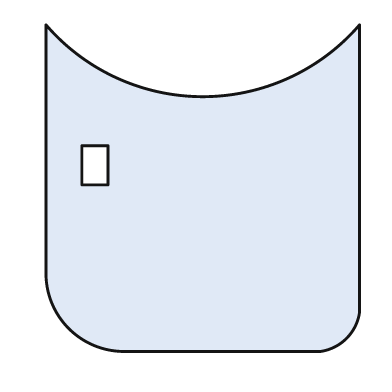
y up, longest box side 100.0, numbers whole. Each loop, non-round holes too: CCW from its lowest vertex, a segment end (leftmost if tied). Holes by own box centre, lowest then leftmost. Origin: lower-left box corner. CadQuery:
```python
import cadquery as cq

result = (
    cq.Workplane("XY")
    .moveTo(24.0, 0.0)
    .lineTo(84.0, 0.0)
    .threePointArc((92.0, 4.0), (96.0, 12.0))
    .lineTo(96.0, 100.0)
    .threePointArc((48.0, 78.0), (0.0, 100.0))
    .lineTo(0.0, 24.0)
    .threePointArc((7.0, 7.0), (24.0, 0.0))
    .close()
    .moveTo(11.0, 51.0)
    .lineTo(19.0, 51.0)
    .lineTo(19.0, 63.0)
    .lineTo(11.0, 63.0)
    .close()
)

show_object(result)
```